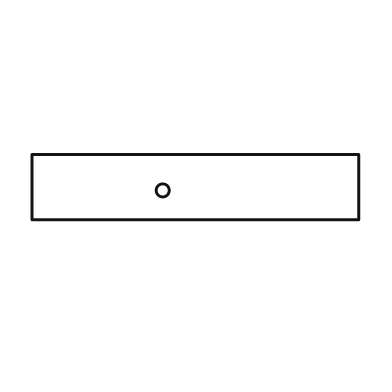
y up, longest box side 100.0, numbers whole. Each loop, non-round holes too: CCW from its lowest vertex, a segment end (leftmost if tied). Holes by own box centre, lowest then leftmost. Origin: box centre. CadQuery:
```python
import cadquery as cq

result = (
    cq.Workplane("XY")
    .moveTo(-50.0, -10.0)
    .lineTo(50.0, -10.0)
    .lineTo(50.0, 10.0)
    .lineTo(-50.0, 10.0)
    .close()
    .moveTo(-10.0, -1.0)
    .circle(2.0)
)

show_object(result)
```